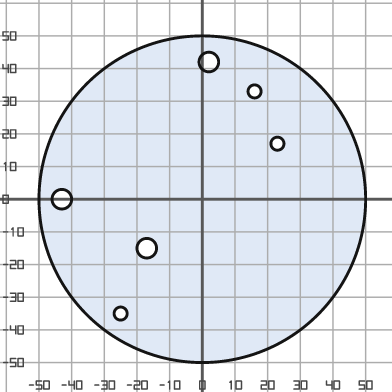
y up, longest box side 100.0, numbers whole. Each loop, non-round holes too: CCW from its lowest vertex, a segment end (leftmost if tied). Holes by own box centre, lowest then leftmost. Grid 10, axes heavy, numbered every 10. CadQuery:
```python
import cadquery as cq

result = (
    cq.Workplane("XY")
    .moveTo(0.0, 0.0)
    .circle(50.0)
    .moveTo(-25.0, -35.0)
    .circle(2.0)
    .moveTo(-17.0, -15.0)
    .circle(3.0)
    .moveTo(-43.0, 0.0)
    .circle(3.0)
    .moveTo(23.0, 17.0)
    .circle(2.0)
    .moveTo(16.0, 33.0)
    .circle(2.0)
    .moveTo(2.0, 42.0)
    .circle(3.0)
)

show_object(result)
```